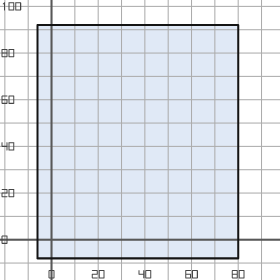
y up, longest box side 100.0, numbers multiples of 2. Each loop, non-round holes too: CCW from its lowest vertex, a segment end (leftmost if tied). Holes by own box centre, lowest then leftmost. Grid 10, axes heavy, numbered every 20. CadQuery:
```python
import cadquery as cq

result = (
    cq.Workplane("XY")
    .moveTo(-6.0, -8.0)
    .lineTo(80.0, -8.0)
    .lineTo(80.0, 92.0)
    .lineTo(-6.0, 92.0)
    .close()
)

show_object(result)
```